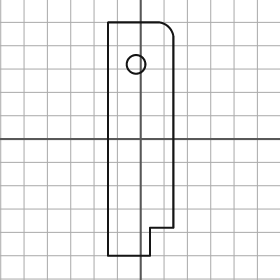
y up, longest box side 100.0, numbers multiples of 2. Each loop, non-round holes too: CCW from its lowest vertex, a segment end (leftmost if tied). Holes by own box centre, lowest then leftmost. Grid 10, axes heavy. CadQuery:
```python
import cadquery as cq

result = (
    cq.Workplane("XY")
    .moveTo(-14.0, -50.0)
    .lineTo(4.0, -50.0)
    .lineTo(4.0, -38.0)
    .lineTo(14.0, -38.0)
    .lineTo(14.0, 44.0)
    .threePointArc((12.0, 48.0), (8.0, 50.0))
    .lineTo(-14.0, 50.0)
    .close()
    .moveTo(-2.0, 32.0)
    .circle(4.0)
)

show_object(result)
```